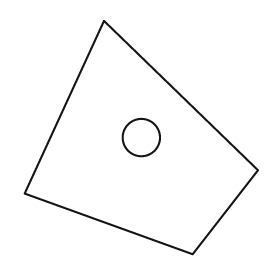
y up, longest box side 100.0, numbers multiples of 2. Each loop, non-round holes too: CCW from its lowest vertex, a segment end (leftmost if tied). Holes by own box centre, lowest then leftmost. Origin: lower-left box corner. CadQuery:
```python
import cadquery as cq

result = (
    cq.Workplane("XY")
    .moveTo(72.0, 0.0)
    .lineTo(100.0, 36.0)
    .lineTo(34.0, 100.0)
    .lineTo(0.0, 26.0)
    .close()
    .moveTo(50.0, 50.0)
    .circle(8.0)
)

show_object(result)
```